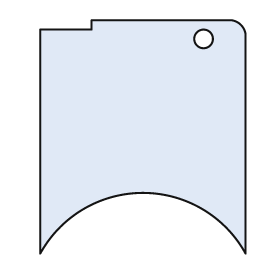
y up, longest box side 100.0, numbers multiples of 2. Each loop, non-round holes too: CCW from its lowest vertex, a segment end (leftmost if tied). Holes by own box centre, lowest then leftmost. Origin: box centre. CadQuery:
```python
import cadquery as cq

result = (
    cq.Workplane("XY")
    .moveTo(-44.0, -50.0)
    .threePointArc((0.0, -24.0), (44.0, -50.0))
    .lineTo(44.0, 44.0)
    .threePointArc((42.0, 48.0), (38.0, 50.0))
    .lineTo(-22.0, 50.0)
    .lineTo(-22.0, 46.0)
    .lineTo(-44.0, 46.0)
    .close()
    .moveTo(26.0, 42.0)
    .circle(4.0)
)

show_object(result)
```